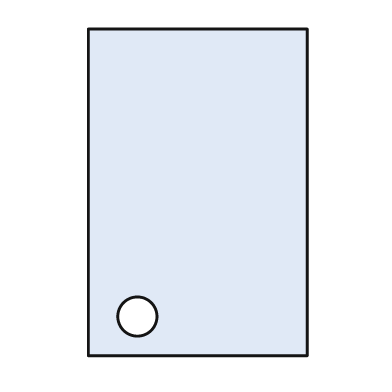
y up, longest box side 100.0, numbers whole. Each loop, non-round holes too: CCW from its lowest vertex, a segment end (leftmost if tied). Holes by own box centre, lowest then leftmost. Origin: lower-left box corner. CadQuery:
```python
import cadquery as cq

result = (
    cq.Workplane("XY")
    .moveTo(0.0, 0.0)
    .lineTo(67.0, 0.0)
    .lineTo(67.0, 100.0)
    .lineTo(0.0, 100.0)
    .close()
    .moveTo(15.0, 12.0)
    .circle(6.0)
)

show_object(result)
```